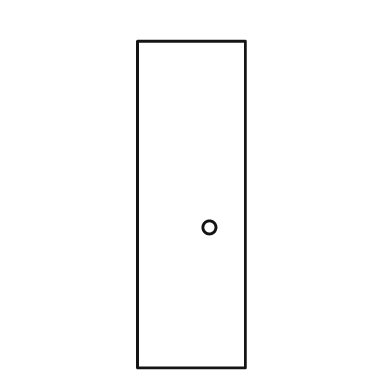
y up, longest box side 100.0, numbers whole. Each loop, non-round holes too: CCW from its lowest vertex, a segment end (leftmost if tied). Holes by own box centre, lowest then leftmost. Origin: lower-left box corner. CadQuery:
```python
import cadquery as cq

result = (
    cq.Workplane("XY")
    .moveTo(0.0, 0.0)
    .lineTo(33.0, 0.0)
    .lineTo(33.0, 100.0)
    .lineTo(0.0, 100.0)
    .close()
    .moveTo(22.0, 43.0)
    .circle(2.0)
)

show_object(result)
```